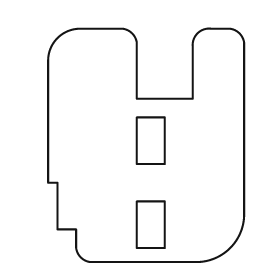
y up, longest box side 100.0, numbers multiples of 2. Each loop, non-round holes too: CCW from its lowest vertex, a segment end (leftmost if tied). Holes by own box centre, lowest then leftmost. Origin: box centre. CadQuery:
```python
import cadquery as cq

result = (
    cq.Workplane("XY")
    .moveTo(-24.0, -50.0)
    .lineTo(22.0, -50.0)
    .threePointArc((36.0, -44.0), (42.0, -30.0))
    .lineTo(42.0, 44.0)
    .threePointArc((40.0, 48.0), (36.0, 50.0))
    .lineTo(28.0, 50.0)
    .threePointArc((22.0, 48.0), (20.0, 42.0))
    .lineTo(20.0, 20.0)
    .lineTo(-4.0, 20.0)
    .lineTo(-4.0, 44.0)
    .threePointArc((-6.0, 48.0), (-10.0, 50.0))
    .lineTo(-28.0, 50.0)
    .threePointArc((-38.0, 46.0), (-42.0, 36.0))
    .lineTo(-42.0, -16.0)
    .lineTo(-38.0, -16.0)
    .lineTo(-38.0, -36.0)
    .lineTo(-30.0, -36.0)
    .lineTo(-30.0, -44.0)
    .threePointArc((-28.0, -48.0), (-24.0, -50.0))
    .close()
    .moveTo(-4.0, -44.0)
    .lineTo(8.0, -44.0)
    .lineTo(8.0, -24.0)
    .lineTo(-4.0, -24.0)
    .close()
    .moveTo(-4.0, -8.0)
    .lineTo(8.0, -8.0)
    .lineTo(8.0, 12.0)
    .lineTo(-4.0, 12.0)
    .close()
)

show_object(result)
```